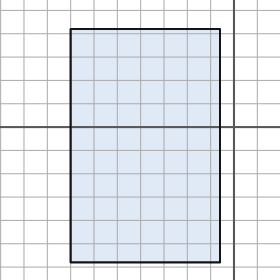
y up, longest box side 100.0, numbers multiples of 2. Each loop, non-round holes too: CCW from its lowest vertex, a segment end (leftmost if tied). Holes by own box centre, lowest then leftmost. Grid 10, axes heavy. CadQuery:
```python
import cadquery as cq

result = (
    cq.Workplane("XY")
    .moveTo(-70.0, -58.0)
    .lineTo(-6.0, -58.0)
    .lineTo(-6.0, 42.0)
    .lineTo(-70.0, 42.0)
    .close()
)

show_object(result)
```